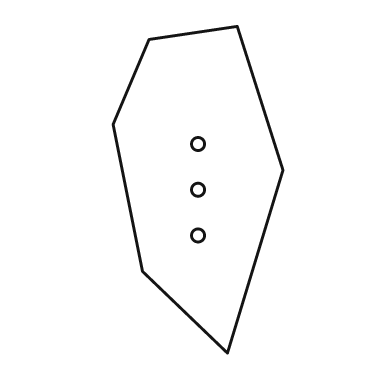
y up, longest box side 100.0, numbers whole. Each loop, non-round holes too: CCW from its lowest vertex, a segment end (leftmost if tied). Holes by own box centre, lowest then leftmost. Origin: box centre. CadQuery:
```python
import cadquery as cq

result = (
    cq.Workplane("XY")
    .moveTo(9.0, -50.0)
    .lineTo(26.0, 6.0)
    .lineTo(12.0, 50.0)
    .lineTo(-15.0, 46.0)
    .lineTo(-26.0, 20.0)
    .lineTo(-17.0, -25.0)
    .close()
    .moveTo(0.0, -14.0)
    .circle(2.0)
    .moveTo(0.0, 0.0)
    .circle(2.0)
    .moveTo(0.0, 14.0)
    .circle(2.0)
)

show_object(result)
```